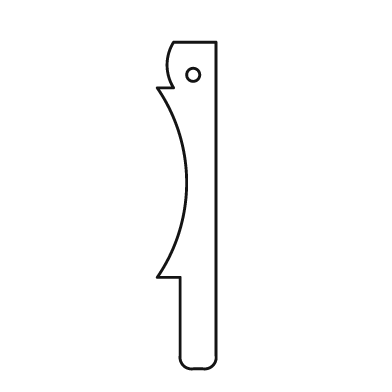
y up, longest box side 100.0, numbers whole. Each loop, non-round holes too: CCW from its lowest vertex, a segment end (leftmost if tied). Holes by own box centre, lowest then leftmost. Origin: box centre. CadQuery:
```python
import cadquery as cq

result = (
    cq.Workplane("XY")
    .moveTo(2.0, -50.0)
    .lineTo(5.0, -50.0)
    .threePointArc((8.0, -49.0), (9.0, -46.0))
    .lineTo(9.0, 50.0)
    .lineTo(-4.0, 50.0)
    .threePointArc((-6.0, 43.0), (-4.0, 36.0))
    .lineTo(-9.0, 36.0)
    .threePointArc((0.0, 7.0), (-9.0, -22.0))
    .lineTo(-2.0, -22.0)
    .lineTo(-2.0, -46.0)
    .threePointArc((-1.0, -49.0), (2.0, -50.0))
    .close()
    .moveTo(2.0, 40.0)
    .circle(2.0)
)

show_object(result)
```